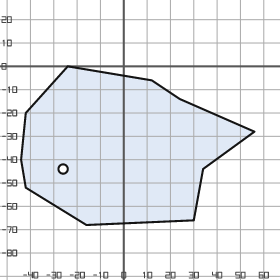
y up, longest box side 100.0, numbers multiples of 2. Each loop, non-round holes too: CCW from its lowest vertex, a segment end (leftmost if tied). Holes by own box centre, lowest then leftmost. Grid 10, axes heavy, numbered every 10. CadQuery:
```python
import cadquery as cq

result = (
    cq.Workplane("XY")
    .moveTo(-16.0, -68.0)
    .lineTo(30.0, -66.0)
    .lineTo(34.0, -44.0)
    .lineTo(56.0, -28.0)
    .lineTo(24.0, -14.0)
    .lineTo(12.0, -6.0)
    .lineTo(-24.0, 0.0)
    .lineTo(-42.0, -20.0)
    .lineTo(-44.0, -40.0)
    .lineTo(-42.0, -52.0)
    .close()
    .moveTo(-26.0, -44.0)
    .circle(2.0)
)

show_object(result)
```